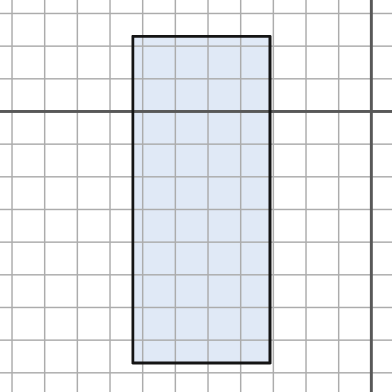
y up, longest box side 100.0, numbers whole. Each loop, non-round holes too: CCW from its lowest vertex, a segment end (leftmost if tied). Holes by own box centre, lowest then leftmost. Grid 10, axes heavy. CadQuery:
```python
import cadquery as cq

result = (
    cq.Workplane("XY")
    .moveTo(-73.0, -77.0)
    .lineTo(-31.0, -77.0)
    .lineTo(-31.0, 23.0)
    .lineTo(-73.0, 23.0)
    .close()
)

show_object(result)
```